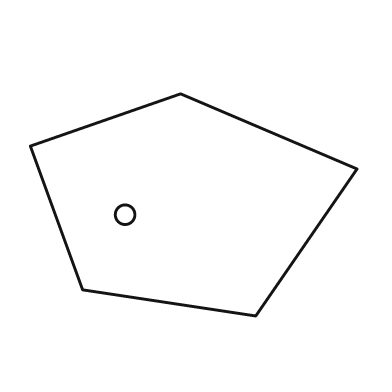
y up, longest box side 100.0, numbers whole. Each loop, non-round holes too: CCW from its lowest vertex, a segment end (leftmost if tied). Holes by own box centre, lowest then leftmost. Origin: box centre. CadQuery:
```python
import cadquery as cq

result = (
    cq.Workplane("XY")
    .moveTo(19.0, -34.0)
    .lineTo(50.0, 11.0)
    .lineTo(-4.0, 34.0)
    .lineTo(-50.0, 18.0)
    .lineTo(-34.0, -26.0)
    .close()
    .moveTo(-21.0, -3.0)
    .circle(3.0)
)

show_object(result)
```